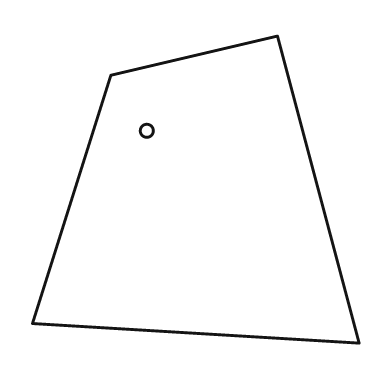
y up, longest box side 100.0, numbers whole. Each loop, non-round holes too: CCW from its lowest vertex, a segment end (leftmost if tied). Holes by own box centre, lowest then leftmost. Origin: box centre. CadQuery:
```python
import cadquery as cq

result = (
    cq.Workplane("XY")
    .moveTo(50.0, -47.0)
    .lineTo(25.0, 47.0)
    .lineTo(-26.0, 35.0)
    .lineTo(-50.0, -41.0)
    .close()
    .moveTo(-15.0, 18.0)
    .circle(2.0)
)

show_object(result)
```